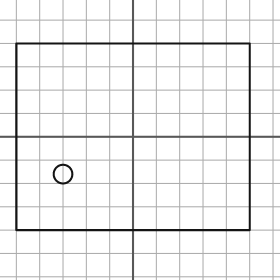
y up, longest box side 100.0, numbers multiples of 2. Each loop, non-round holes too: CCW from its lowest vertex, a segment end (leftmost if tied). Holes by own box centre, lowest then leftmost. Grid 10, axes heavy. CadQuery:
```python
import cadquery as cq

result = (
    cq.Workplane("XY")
    .moveTo(-50.0, -40.0)
    .lineTo(50.0, -40.0)
    .lineTo(50.0, 40.0)
    .lineTo(-50.0, 40.0)
    .close()
    .moveTo(-30.0, -16.0)
    .circle(4.0)
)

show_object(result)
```